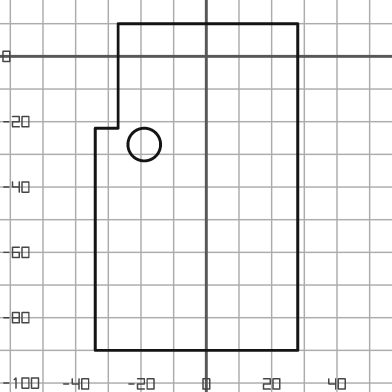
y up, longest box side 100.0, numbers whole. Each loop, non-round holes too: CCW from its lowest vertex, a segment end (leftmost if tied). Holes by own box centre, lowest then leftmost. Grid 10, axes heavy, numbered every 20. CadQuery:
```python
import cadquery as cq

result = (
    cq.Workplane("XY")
    .moveTo(-34.0, -90.0)
    .lineTo(28.0, -90.0)
    .lineTo(28.0, 10.0)
    .lineTo(-27.0, 10.0)
    .lineTo(-27.0, -22.0)
    .lineTo(-34.0, -22.0)
    .close()
    .moveTo(-19.0, -27.0)
    .circle(5.0)
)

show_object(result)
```